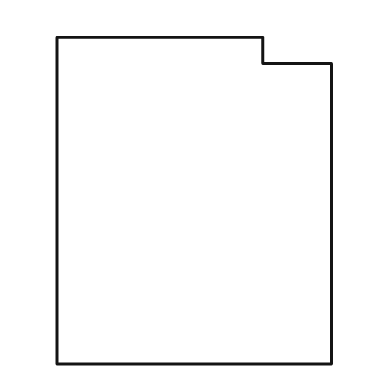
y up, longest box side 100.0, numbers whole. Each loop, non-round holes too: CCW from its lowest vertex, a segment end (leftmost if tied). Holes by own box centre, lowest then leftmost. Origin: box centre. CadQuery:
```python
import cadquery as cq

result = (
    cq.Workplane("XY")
    .moveTo(-42.0, -50.0)
    .lineTo(42.0, -50.0)
    .lineTo(42.0, 42.0)
    .lineTo(21.0, 42.0)
    .lineTo(21.0, 50.0)
    .lineTo(-42.0, 50.0)
    .close()
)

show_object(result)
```